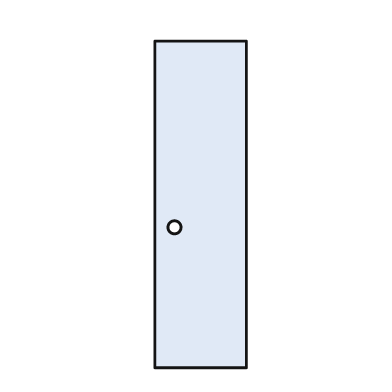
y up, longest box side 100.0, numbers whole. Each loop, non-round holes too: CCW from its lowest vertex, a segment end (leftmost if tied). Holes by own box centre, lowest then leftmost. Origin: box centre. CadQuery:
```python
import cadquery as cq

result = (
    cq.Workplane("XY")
    .moveTo(-14.0, -50.0)
    .lineTo(14.0, -50.0)
    .lineTo(14.0, 50.0)
    .lineTo(-14.0, 50.0)
    .close()
    .moveTo(-8.0, -7.0)
    .circle(2.0)
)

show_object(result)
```